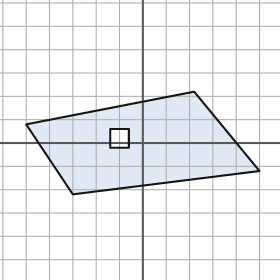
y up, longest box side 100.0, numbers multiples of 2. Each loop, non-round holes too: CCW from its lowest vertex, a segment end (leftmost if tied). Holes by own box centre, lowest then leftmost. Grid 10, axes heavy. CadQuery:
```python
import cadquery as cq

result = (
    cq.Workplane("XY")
    .moveTo(-30.0, -22.0)
    .lineTo(50.0, -12.0)
    .lineTo(22.0, 22.0)
    .lineTo(-50.0, 8.0)
    .close()
    .moveTo(-14.0, -2.0)
    .lineTo(-6.0, -2.0)
    .lineTo(-6.0, 6.0)
    .lineTo(-14.0, 6.0)
    .close()
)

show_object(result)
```